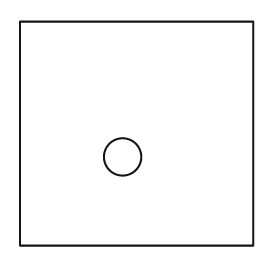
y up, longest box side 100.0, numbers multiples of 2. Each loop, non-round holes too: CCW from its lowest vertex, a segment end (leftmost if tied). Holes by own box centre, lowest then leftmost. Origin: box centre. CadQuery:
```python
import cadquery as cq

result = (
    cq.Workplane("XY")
    .moveTo(-50.0, -48.0)
    .lineTo(50.0, -48.0)
    .lineTo(50.0, 48.0)
    .lineTo(-50.0, 48.0)
    .close()
    .moveTo(-6.0, -10.0)
    .circle(8.0)
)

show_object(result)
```